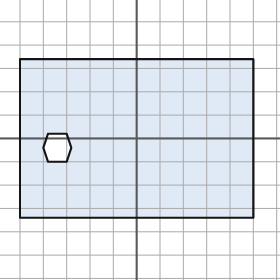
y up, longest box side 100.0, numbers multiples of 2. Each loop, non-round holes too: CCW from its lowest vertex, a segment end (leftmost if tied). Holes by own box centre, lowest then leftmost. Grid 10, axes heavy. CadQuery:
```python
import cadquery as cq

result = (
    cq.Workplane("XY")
    .moveTo(-50.0, -34.0)
    .lineTo(50.0, -34.0)
    .lineTo(50.0, 34.0)
    .lineTo(-50.0, 34.0)
    .close()
    .moveTo(-38.0, -10.0)
    .lineTo(-30.0, -10.0)
    .lineTo(-28.0, -4.0)
    .lineTo(-30.0, 2.0)
    .lineTo(-38.0, 2.0)
    .lineTo(-40.0, -4.0)
    .close()
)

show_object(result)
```